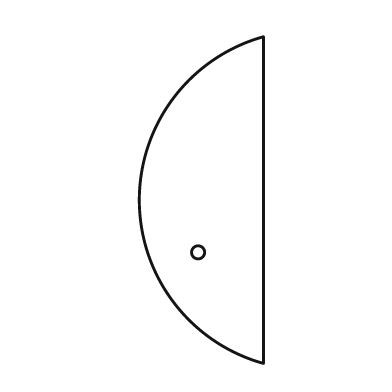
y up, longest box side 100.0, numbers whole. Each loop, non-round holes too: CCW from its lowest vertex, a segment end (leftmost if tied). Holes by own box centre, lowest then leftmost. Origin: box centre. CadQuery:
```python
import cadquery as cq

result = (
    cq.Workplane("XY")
    .moveTo(19.0, -50.0)
    .lineTo(19.0, 50.0)
    .threePointArc((-19.0, 0.0), (19.0, -50.0))
    .close()
    .moveTo(-1.0, -16.0)
    .circle(2.0)
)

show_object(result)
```